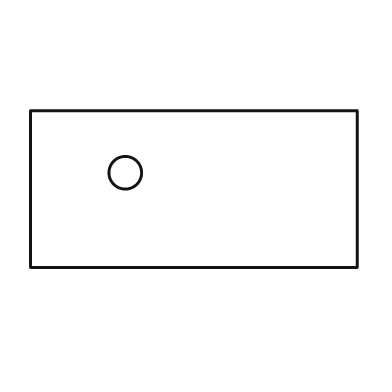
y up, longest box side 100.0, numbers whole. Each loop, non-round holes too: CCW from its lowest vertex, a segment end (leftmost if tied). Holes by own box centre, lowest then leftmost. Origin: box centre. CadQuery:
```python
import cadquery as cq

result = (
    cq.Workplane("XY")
    .moveTo(-50.0, -24.0)
    .lineTo(50.0, -24.0)
    .lineTo(50.0, 24.0)
    .lineTo(-50.0, 24.0)
    .close()
    .moveTo(-21.0, 5.0)
    .circle(5.0)
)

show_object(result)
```